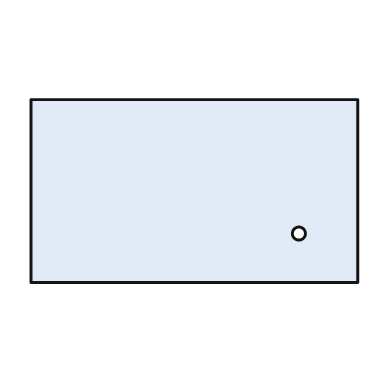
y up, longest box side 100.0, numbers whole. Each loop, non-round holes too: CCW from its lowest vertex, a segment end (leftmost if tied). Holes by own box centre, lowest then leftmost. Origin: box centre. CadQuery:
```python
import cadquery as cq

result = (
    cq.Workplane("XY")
    .moveTo(-50.0, -28.0)
    .lineTo(50.0, -28.0)
    .lineTo(50.0, 28.0)
    .lineTo(-50.0, 28.0)
    .close()
    .moveTo(32.0, -13.0)
    .circle(2.0)
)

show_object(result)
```